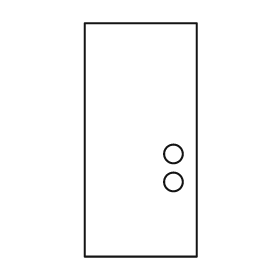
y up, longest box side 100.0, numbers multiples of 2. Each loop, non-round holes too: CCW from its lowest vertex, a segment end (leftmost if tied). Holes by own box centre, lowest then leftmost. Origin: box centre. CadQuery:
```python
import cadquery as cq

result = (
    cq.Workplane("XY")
    .moveTo(-24.0, -50.0)
    .lineTo(24.0, -50.0)
    .lineTo(24.0, 50.0)
    .lineTo(-24.0, 50.0)
    .close()
    .moveTo(14.0, -18.0)
    .circle(4.0)
    .moveTo(14.0, -6.0)
    .circle(4.0)
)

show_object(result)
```